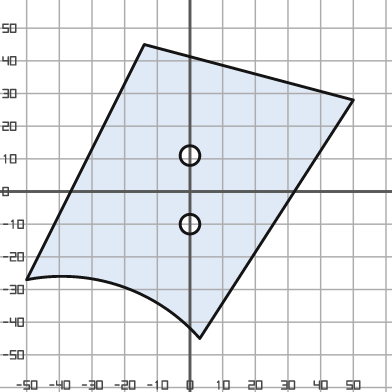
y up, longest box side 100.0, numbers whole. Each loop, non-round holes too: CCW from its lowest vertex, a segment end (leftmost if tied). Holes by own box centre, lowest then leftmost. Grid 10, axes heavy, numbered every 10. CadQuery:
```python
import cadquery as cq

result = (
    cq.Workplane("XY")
    .moveTo(3.0, -45.0)
    .lineTo(50.0, 28.0)
    .lineTo(-14.0, 45.0)
    .lineTo(-50.0, -27.0)
    .threePointArc((-21.0, -29.0), (3.0, -45.0))
    .close()
    .moveTo(0.0, -10.0)
    .circle(3.0)
    .moveTo(0.0, 11.0)
    .circle(3.0)
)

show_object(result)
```